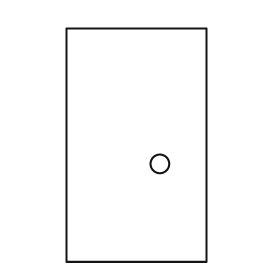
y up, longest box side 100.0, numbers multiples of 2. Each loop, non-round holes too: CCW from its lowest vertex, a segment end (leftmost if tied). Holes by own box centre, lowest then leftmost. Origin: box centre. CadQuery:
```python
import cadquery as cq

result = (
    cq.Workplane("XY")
    .moveTo(-30.0, -50.0)
    .lineTo(30.0, -50.0)
    .lineTo(30.0, 50.0)
    .lineTo(-30.0, 50.0)
    .close()
    .moveTo(10.0, -8.0)
    .circle(4.0)
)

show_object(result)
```